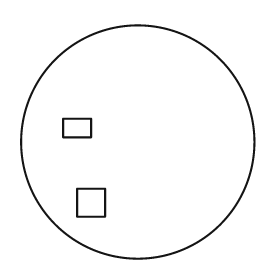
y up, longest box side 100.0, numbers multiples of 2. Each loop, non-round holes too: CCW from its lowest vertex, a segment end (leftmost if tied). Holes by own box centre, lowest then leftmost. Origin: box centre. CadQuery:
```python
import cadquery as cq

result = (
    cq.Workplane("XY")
    .moveTo(0.0, 0.0)
    .circle(50.0)
    .moveTo(-26.0, -32.0)
    .lineTo(-14.0, -32.0)
    .lineTo(-14.0, -20.0)
    .lineTo(-26.0, -20.0)
    .close()
    .moveTo(-32.0, 2.0)
    .lineTo(-20.0, 2.0)
    .lineTo(-20.0, 10.0)
    .lineTo(-32.0, 10.0)
    .close()
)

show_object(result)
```